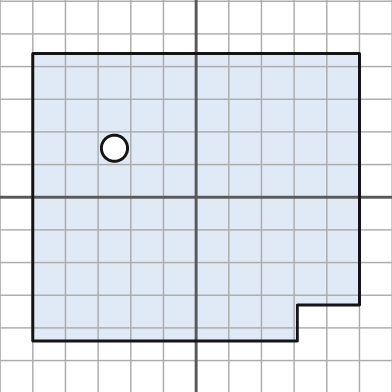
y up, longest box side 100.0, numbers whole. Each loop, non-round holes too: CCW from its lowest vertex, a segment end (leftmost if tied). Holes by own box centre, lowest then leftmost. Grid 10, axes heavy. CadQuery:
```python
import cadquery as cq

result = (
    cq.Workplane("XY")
    .moveTo(-50.0, -44.0)
    .lineTo(31.0, -44.0)
    .lineTo(31.0, -33.0)
    .lineTo(50.0, -33.0)
    .lineTo(50.0, 44.0)
    .lineTo(-50.0, 44.0)
    .close()
    .moveTo(-25.0, 15.0)
    .circle(4.0)
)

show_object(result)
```